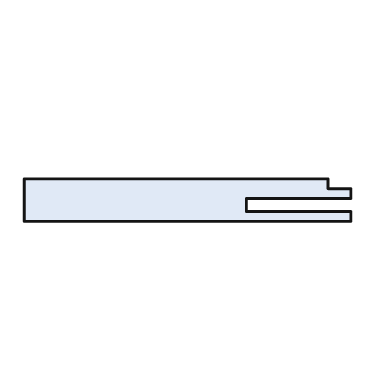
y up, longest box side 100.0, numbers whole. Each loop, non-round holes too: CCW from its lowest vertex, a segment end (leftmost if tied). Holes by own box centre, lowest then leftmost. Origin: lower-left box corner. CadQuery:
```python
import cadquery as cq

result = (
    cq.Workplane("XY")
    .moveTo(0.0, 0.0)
    .lineTo(100.0, 0.0)
    .lineTo(100.0, 3.0)
    .lineTo(68.0, 3.0)
    .lineTo(68.0, 7.0)
    .lineTo(100.0, 7.0)
    .lineTo(100.0, 10.0)
    .lineTo(93.0, 10.0)
    .lineTo(93.0, 13.0)
    .lineTo(0.0, 13.0)
    .close()
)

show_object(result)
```